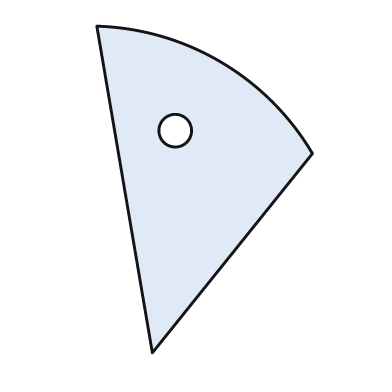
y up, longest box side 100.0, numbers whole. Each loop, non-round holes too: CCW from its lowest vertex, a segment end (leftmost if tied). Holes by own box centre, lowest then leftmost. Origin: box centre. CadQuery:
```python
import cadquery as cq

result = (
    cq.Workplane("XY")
    .moveTo(-16.0, -50.0)
    .lineTo(33.0, 11.0)
    .threePointArc((5.0, 39.0), (-33.0, 50.0))
    .close()
    .moveTo(-9.0, 18.0)
    .circle(5.0)
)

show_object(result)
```